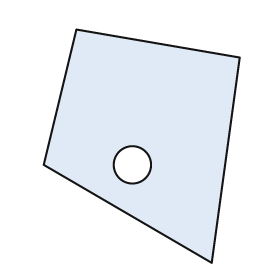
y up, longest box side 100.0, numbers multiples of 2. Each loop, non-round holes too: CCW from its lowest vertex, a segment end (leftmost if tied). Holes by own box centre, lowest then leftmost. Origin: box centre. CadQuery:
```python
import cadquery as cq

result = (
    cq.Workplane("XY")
    .moveTo(30.0, -50.0)
    .lineTo(42.0, 38.0)
    .lineTo(-28.0, 50.0)
    .lineTo(-42.0, -8.0)
    .close()
    .moveTo(-4.0, -8.0)
    .circle(8.0)
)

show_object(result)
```